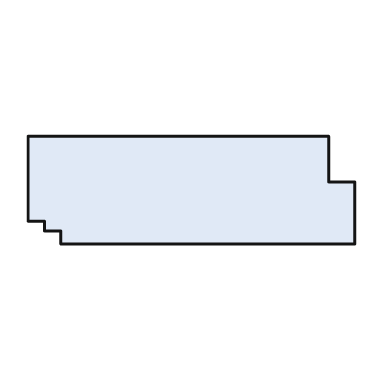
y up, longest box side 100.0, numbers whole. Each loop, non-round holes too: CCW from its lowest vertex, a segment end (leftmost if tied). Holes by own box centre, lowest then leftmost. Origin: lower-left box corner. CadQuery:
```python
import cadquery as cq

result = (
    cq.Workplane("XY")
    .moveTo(10.0, 0.0)
    .lineTo(100.0, 0.0)
    .lineTo(100.0, 19.0)
    .lineTo(92.0, 19.0)
    .lineTo(92.0, 33.0)
    .lineTo(0.0, 33.0)
    .lineTo(0.0, 7.0)
    .lineTo(5.0, 7.0)
    .lineTo(5.0, 4.0)
    .lineTo(10.0, 4.0)
    .close()
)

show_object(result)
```